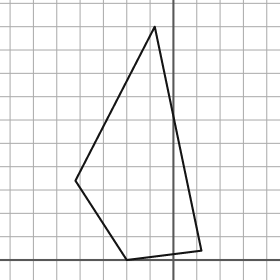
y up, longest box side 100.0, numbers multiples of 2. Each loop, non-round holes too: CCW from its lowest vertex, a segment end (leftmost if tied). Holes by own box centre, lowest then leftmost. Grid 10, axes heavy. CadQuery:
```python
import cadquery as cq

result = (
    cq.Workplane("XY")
    .moveTo(-20.0, 0.0)
    .lineTo(12.0, 4.0)
    .lineTo(-8.0, 100.0)
    .lineTo(-42.0, 34.0)
    .close()
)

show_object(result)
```